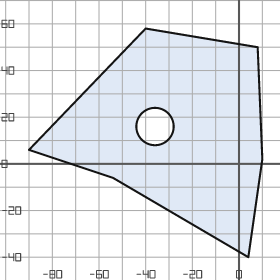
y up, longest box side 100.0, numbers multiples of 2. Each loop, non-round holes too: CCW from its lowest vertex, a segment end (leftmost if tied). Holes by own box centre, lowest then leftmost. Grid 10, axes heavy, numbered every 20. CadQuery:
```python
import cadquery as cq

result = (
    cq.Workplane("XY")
    .moveTo(4.0, -40.0)
    .lineTo(10.0, 2.0)
    .lineTo(8.0, 50.0)
    .lineTo(-40.0, 58.0)
    .lineTo(-90.0, 6.0)
    .lineTo(-54.0, -6.0)
    .close()
    .moveTo(-36.0, 16.0)
    .circle(8.0)
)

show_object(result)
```